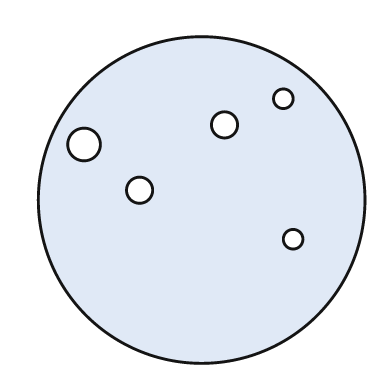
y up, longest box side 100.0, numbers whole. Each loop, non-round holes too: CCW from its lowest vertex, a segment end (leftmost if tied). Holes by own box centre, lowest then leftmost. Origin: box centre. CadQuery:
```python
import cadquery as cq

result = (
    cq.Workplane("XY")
    .moveTo(0.0, 0.0)
    .circle(50.0)
    .moveTo(28.0, -12.0)
    .circle(3.0)
    .moveTo(-19.0, 3.0)
    .circle(4.0)
    .moveTo(-36.0, 17.0)
    .circle(5.0)
    .moveTo(7.0, 23.0)
    .circle(4.0)
    .moveTo(25.0, 31.0)
    .circle(3.0)
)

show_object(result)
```